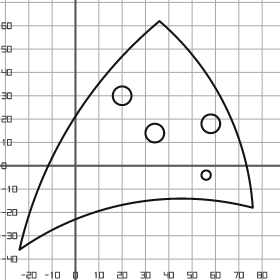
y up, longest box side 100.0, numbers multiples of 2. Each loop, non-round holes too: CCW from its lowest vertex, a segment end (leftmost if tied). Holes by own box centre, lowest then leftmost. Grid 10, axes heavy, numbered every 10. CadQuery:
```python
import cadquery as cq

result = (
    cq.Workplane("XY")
    .moveTo(-24.0, -36.0)
    .threePointArc((24.0, -16.0), (76.0, -18.0))
    .threePointArc((64.0, 26.0), (36.0, 62.0))
    .threePointArc((-2.0, 18.0), (-24.0, -36.0))
    .close()
    .moveTo(56.0, -4.0)
    .circle(2.0)
    .moveTo(34.0, 14.0)
    .circle(4.0)
    .moveTo(58.0, 18.0)
    .circle(4.0)
    .moveTo(20.0, 30.0)
    .circle(4.0)
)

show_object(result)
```